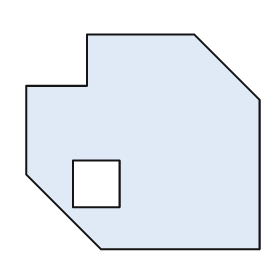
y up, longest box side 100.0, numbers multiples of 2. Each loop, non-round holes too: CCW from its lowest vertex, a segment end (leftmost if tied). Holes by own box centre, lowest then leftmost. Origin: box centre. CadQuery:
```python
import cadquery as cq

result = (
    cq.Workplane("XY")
    .moveTo(-18.0, -46.0)
    .lineTo(50.0, -46.0)
    .lineTo(50.0, 18.0)
    .lineTo(22.0, 46.0)
    .lineTo(-24.0, 46.0)
    .lineTo(-24.0, 24.0)
    .lineTo(-50.0, 24.0)
    .lineTo(-50.0, -14.0)
    .close()
    .moveTo(-30.0, -28.0)
    .lineTo(-10.0, -28.0)
    .lineTo(-10.0, -8.0)
    .lineTo(-30.0, -8.0)
    .close()
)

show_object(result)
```